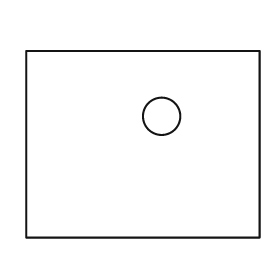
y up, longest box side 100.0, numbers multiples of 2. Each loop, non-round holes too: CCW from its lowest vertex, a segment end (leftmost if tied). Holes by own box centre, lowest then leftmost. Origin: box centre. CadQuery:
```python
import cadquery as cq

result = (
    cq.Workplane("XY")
    .moveTo(-50.0, -40.0)
    .lineTo(50.0, -40.0)
    .lineTo(50.0, 40.0)
    .lineTo(-50.0, 40.0)
    .close()
    .moveTo(8.0, 12.0)
    .circle(8.0)
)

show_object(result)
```